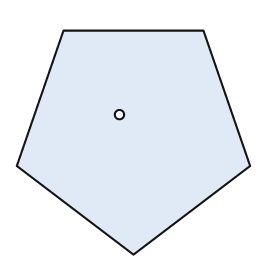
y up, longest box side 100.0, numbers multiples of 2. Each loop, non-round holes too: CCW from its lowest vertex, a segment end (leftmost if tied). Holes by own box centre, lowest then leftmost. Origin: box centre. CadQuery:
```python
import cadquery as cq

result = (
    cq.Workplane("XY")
    .moveTo(0.0, -48.0)
    .lineTo(50.0, -10.0)
    .lineTo(30.0, 48.0)
    .lineTo(-30.0, 48.0)
    .lineTo(-50.0, -10.0)
    .close()
    .moveTo(-6.0, 12.0)
    .circle(2.0)
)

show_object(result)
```